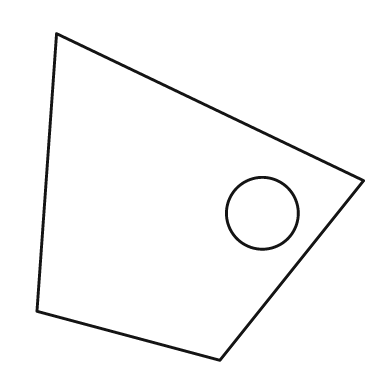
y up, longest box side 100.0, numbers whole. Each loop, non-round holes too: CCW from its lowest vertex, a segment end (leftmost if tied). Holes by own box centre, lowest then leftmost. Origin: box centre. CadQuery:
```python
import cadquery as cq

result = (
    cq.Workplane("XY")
    .moveTo(6.0, -50.0)
    .lineTo(50.0, 5.0)
    .lineTo(-44.0, 50.0)
    .lineTo(-50.0, -35.0)
    .close()
    .moveTo(19.0, -5.0)
    .circle(11.0)
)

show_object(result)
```